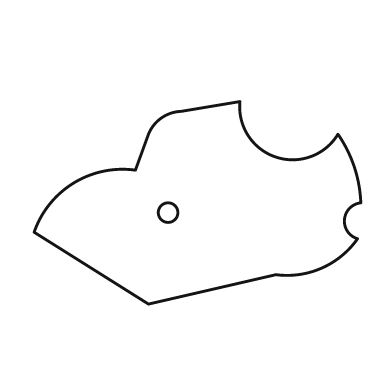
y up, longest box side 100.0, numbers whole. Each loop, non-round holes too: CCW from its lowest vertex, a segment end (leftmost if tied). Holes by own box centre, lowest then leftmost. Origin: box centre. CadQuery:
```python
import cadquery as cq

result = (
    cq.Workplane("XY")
    .moveTo(-15.0, -31.0)
    .lineTo(24.0, -22.0)
    .threePointArc((38.0, -20.0), (49.0, -11.0))
    .threePointArc((45.0, -5.0), (50.0, 0.0))
    .threePointArc((48.0, 11.0), (43.0, 21.0))
    .threePointArc((24.0, 14.0), (13.0, 31.0))
    .lineTo(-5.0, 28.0)
    .threePointArc((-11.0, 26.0), (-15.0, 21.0))
    .lineTo(-19.0, 10.0)
    .threePointArc((-38.0, 6.0), (-50.0, -9.0))
    .close()
    .moveTo(-9.0, -3.0)
    .circle(3.0)
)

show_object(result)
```